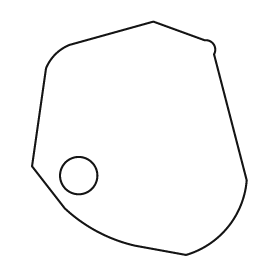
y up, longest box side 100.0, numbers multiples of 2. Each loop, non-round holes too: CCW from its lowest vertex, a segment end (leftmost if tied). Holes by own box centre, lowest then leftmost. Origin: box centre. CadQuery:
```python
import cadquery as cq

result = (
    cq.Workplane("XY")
    .moveTo(20.0, -50.0)
    .threePointArc((38.0, -38.0), (46.0, -18.0))
    .lineTo(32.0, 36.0)
    .threePointArc((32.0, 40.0), (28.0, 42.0))
    .lineTo(6.0, 50.0)
    .lineTo(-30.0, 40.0)
    .threePointArc((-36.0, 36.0), (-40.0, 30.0))
    .lineTo(-46.0, -12.0)
    .lineTo(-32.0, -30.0)
    .threePointArc((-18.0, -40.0), (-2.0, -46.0))
    .close()
    .moveTo(-26.0, -16.0)
    .circle(8.0)
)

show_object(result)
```